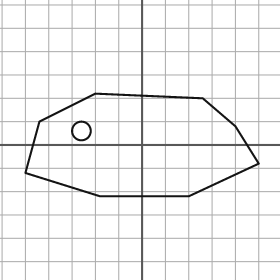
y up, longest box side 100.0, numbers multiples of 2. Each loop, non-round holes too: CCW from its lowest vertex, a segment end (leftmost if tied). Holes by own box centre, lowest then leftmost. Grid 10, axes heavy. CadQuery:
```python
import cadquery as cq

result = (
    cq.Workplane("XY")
    .moveTo(-18.0, -22.0)
    .lineTo(20.0, -22.0)
    .lineTo(50.0, -8.0)
    .lineTo(40.0, 8.0)
    .lineTo(26.0, 20.0)
    .lineTo(-20.0, 22.0)
    .lineTo(-44.0, 10.0)
    .lineTo(-50.0, -12.0)
    .close()
    .moveTo(-26.0, 6.0)
    .circle(4.0)
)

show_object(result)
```